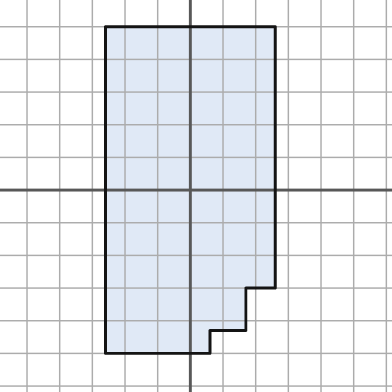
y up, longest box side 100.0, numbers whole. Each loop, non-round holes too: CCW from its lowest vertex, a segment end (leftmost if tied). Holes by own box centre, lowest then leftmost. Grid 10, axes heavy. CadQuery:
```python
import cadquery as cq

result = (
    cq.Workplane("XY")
    .moveTo(-26.0, -50.0)
    .lineTo(6.0, -50.0)
    .lineTo(6.0, -43.0)
    .lineTo(17.0, -43.0)
    .lineTo(17.0, -30.0)
    .lineTo(26.0, -30.0)
    .lineTo(26.0, 50.0)
    .lineTo(-26.0, 50.0)
    .close()
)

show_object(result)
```